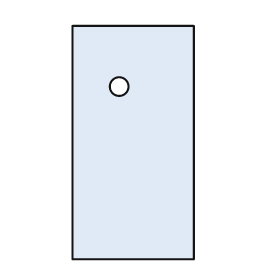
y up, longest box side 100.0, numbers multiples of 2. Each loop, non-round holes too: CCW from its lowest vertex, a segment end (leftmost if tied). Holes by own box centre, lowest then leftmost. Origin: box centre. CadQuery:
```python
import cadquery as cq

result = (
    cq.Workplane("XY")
    .moveTo(-26.0, -50.0)
    .lineTo(26.0, -50.0)
    .lineTo(26.0, 50.0)
    .lineTo(-26.0, 50.0)
    .close()
    .moveTo(-6.0, 24.0)
    .circle(4.0)
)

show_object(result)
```